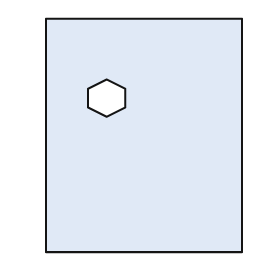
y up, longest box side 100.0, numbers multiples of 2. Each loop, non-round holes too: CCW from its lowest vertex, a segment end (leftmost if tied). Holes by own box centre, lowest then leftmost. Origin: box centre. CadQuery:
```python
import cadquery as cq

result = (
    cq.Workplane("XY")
    .moveTo(-42.0, -50.0)
    .lineTo(42.0, -50.0)
    .lineTo(42.0, 50.0)
    .lineTo(-42.0, 50.0)
    .close()
    .moveTo(-16.0, 8.0)
    .lineTo(-8.0, 12.0)
    .lineTo(-8.0, 20.0)
    .lineTo(-16.0, 24.0)
    .lineTo(-24.0, 20.0)
    .lineTo(-24.0, 12.0)
    .close()
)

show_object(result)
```